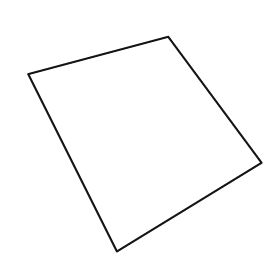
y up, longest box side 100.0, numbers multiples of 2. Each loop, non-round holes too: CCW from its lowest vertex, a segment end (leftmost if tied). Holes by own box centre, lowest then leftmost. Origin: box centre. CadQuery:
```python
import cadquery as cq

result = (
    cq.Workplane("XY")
    .moveTo(-12.0, -46.0)
    .lineTo(50.0, -8.0)
    .lineTo(10.0, 46.0)
    .lineTo(-50.0, 30.0)
    .close()
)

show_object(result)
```